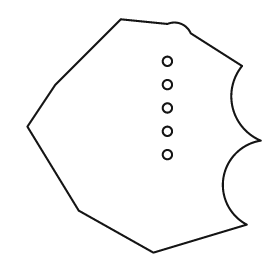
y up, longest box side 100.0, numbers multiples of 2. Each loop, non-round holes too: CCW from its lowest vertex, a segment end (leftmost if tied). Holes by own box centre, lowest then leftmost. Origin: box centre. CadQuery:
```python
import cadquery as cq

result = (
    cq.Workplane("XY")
    .moveTo(4.0, -50.0)
    .lineTo(44.0, -38.0)
    .threePointArc((34.0, -18.0), (50.0, -2.0))
    .threePointArc((38.0, 12.0), (42.0, 30.0))
    .lineTo(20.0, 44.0)
    .threePointArc((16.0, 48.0), (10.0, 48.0))
    .lineTo(-10.0, 50.0)
    .lineTo(-38.0, 22.0)
    .lineTo(-50.0, 4.0)
    .lineTo(-28.0, -32.0)
    .close()
    .moveTo(10.0, -8.0)
    .circle(2.0)
    .moveTo(10.0, 2.0)
    .circle(2.0)
    .moveTo(10.0, 12.0)
    .circle(2.0)
    .moveTo(10.0, 22.0)
    .circle(2.0)
    .moveTo(10.0, 32.0)
    .circle(2.0)
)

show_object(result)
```